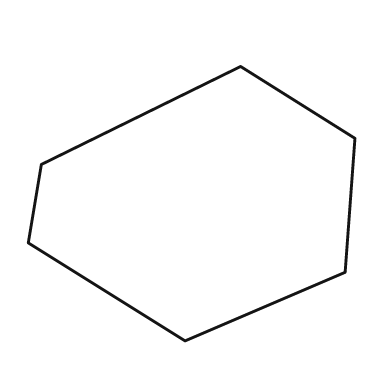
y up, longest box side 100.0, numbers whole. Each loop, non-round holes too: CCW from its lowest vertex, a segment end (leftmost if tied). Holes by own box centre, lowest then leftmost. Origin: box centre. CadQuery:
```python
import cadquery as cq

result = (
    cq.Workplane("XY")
    .moveTo(-2.0, -42.0)
    .lineTo(47.0, -21.0)
    .lineTo(50.0, 20.0)
    .lineTo(15.0, 42.0)
    .lineTo(-46.0, 12.0)
    .lineTo(-50.0, -12.0)
    .close()
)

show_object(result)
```